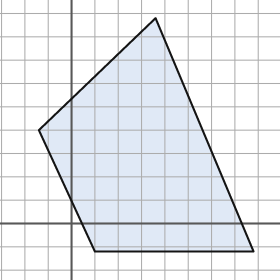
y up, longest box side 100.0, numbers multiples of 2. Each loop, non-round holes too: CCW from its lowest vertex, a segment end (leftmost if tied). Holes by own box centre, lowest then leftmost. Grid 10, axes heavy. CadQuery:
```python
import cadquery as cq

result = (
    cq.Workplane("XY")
    .moveTo(10.0, -12.0)
    .lineTo(78.0, -12.0)
    .lineTo(36.0, 88.0)
    .lineTo(-14.0, 40.0)
    .close()
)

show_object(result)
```